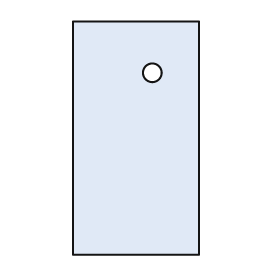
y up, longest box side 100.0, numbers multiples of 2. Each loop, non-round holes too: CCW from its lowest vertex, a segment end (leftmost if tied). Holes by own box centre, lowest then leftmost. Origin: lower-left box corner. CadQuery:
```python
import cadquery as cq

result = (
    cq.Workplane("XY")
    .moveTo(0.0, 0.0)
    .lineTo(54.0, 0.0)
    .lineTo(54.0, 100.0)
    .lineTo(0.0, 100.0)
    .close()
    .moveTo(34.0, 78.0)
    .circle(4.0)
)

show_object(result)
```